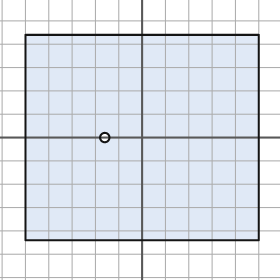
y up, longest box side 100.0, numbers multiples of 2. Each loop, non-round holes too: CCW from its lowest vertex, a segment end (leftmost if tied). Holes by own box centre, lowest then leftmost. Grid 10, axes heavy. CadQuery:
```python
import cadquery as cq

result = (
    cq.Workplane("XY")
    .moveTo(-50.0, -44.0)
    .lineTo(50.0, -44.0)
    .lineTo(50.0, 44.0)
    .lineTo(-50.0, 44.0)
    .close()
    .moveTo(-16.0, 0.0)
    .circle(2.0)
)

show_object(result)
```